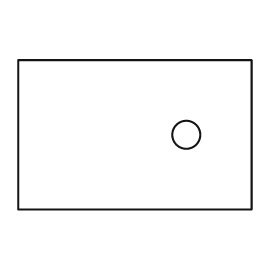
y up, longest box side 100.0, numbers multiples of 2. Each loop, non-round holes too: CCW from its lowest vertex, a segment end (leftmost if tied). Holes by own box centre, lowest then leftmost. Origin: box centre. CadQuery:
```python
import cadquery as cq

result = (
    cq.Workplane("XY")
    .moveTo(-50.0, -32.0)
    .lineTo(50.0, -32.0)
    .lineTo(50.0, 32.0)
    .lineTo(-50.0, 32.0)
    .close()
    .moveTo(22.0, 0.0)
    .circle(6.0)
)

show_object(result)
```